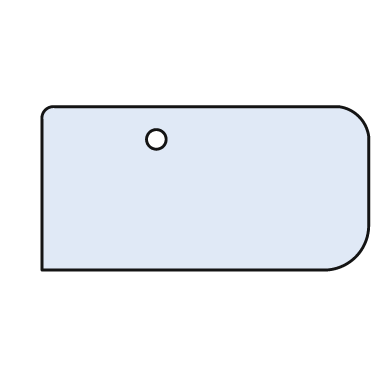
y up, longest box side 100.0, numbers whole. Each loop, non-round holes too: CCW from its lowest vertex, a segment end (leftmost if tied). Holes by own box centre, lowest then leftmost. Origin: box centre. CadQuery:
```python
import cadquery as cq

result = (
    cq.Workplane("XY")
    .moveTo(-50.0, -25.0)
    .lineTo(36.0, -25.0)
    .threePointArc((46.0, -21.0), (50.0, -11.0))
    .lineTo(50.0, 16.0)
    .threePointArc((47.0, 22.0), (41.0, 25.0))
    .lineTo(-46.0, 25.0)
    .threePointArc((-49.0, 24.0), (-50.0, 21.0))
    .close()
    .moveTo(-15.0, 15.0)
    .circle(3.0)
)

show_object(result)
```